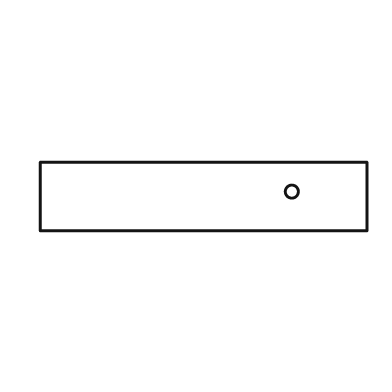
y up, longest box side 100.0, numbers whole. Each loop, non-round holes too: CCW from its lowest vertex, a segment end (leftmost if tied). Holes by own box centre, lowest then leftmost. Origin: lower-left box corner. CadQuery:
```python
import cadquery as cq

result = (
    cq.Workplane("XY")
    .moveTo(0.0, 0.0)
    .lineTo(100.0, 0.0)
    .lineTo(100.0, 21.0)
    .lineTo(0.0, 21.0)
    .close()
    .moveTo(77.0, 12.0)
    .circle(2.0)
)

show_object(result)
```